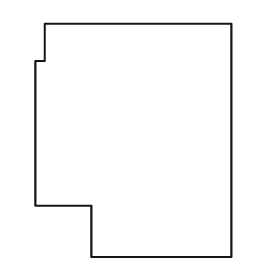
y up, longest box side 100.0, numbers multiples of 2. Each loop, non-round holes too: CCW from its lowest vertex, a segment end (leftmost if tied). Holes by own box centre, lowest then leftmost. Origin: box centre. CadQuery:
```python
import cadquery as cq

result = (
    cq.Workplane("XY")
    .moveTo(-18.0, -50.0)
    .lineTo(42.0, -50.0)
    .lineTo(42.0, 50.0)
    .lineTo(-38.0, 50.0)
    .lineTo(-38.0, 34.0)
    .lineTo(-42.0, 34.0)
    .lineTo(-42.0, -28.0)
    .lineTo(-18.0, -28.0)
    .close()
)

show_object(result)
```